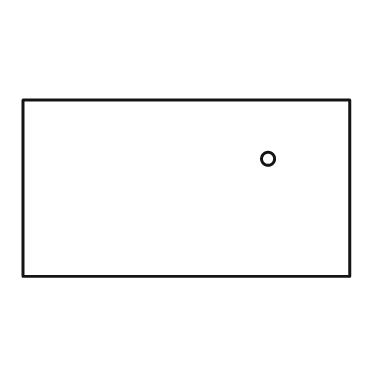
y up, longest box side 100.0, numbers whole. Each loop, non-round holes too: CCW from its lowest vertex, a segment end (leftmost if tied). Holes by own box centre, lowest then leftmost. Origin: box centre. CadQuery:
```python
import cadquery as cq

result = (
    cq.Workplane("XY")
    .moveTo(-50.0, -27.0)
    .lineTo(50.0, -27.0)
    .lineTo(50.0, 27.0)
    .lineTo(-50.0, 27.0)
    .close()
    .moveTo(25.0, 9.0)
    .circle(2.0)
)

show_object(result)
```